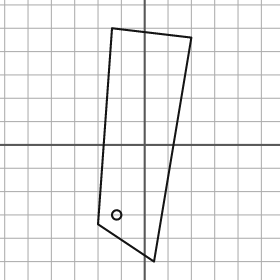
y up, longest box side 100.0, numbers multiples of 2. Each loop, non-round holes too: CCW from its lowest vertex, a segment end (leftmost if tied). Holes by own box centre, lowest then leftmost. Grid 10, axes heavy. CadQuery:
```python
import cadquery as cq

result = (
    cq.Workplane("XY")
    .moveTo(4.0, -50.0)
    .lineTo(20.0, 46.0)
    .lineTo(-14.0, 50.0)
    .lineTo(-20.0, -34.0)
    .close()
    .moveTo(-12.0, -30.0)
    .circle(2.0)
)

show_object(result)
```